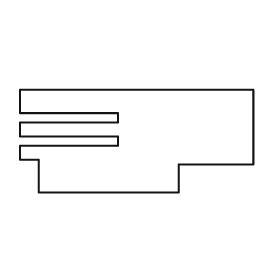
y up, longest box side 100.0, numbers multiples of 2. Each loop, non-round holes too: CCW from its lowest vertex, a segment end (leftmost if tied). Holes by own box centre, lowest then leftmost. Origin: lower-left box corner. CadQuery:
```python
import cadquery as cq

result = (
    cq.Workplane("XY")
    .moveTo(8.0, 0.0)
    .lineTo(68.0, 0.0)
    .lineTo(68.0, 12.0)
    .lineTo(100.0, 12.0)
    .lineTo(100.0, 44.0)
    .lineTo(0.0, 44.0)
    .lineTo(0.0, 34.0)
    .lineTo(42.0, 34.0)
    .lineTo(42.0, 30.0)
    .lineTo(0.0, 30.0)
    .lineTo(0.0, 24.0)
    .lineTo(42.0, 24.0)
    .lineTo(42.0, 20.0)
    .lineTo(0.0, 20.0)
    .lineTo(0.0, 14.0)
    .lineTo(8.0, 14.0)
    .close()
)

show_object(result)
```